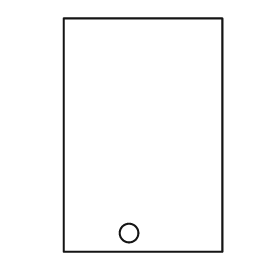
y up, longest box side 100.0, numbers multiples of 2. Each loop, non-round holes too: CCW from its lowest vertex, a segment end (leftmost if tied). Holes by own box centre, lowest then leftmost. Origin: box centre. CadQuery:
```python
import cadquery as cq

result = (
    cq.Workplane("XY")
    .moveTo(-34.0, -50.0)
    .lineTo(34.0, -50.0)
    .lineTo(34.0, 50.0)
    .lineTo(-34.0, 50.0)
    .close()
    .moveTo(-6.0, -42.0)
    .circle(4.0)
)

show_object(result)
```